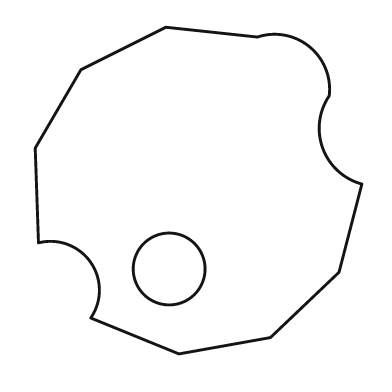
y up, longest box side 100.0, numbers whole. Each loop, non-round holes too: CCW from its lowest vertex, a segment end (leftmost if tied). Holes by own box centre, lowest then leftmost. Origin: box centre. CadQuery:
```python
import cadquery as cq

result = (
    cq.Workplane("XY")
    .moveTo(-6.0, -50.0)
    .lineTo(22.0, -45.0)
    .lineTo(43.0, -25.0)
    .lineTo(50.0, 2.0)
    .threePointArc((38.0, 13.0), (40.0, 29.0))
    .threePointArc((34.0, 44.0), (18.0, 47.0))
    .lineTo(-10.0, 50.0)
    .lineTo(-36.0, 37.0)
    .lineTo(-50.0, 13.0)
    .lineTo(-49.0, -16.0)
    .threePointArc((-33.0, -22.0), (-33.0, -39.0))
    .close()
    .moveTo(-9.0, -24.0)
    .circle(11.0)
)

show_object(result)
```